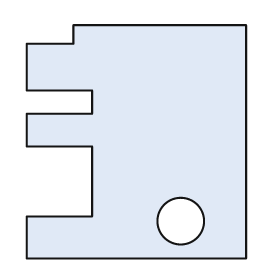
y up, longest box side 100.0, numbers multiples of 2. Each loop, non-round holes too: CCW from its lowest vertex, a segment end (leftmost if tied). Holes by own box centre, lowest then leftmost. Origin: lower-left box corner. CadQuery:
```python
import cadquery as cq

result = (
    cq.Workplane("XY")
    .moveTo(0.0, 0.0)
    .lineTo(94.0, 0.0)
    .lineTo(94.0, 100.0)
    .lineTo(20.0, 100.0)
    .lineTo(20.0, 92.0)
    .lineTo(0.0, 92.0)
    .lineTo(0.0, 72.0)
    .lineTo(28.0, 72.0)
    .lineTo(28.0, 62.0)
    .lineTo(0.0, 62.0)
    .lineTo(0.0, 48.0)
    .lineTo(28.0, 48.0)
    .lineTo(28.0, 18.0)
    .lineTo(0.0, 18.0)
    .close()
    .moveTo(66.0, 16.0)
    .circle(10.0)
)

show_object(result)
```